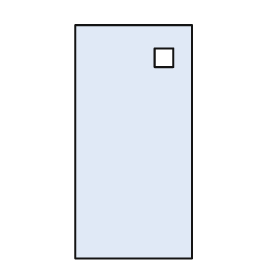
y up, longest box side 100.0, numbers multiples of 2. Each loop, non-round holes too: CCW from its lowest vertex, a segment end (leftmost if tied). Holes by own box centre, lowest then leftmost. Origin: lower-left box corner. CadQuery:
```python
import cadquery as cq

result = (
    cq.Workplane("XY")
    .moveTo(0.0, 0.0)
    .lineTo(50.0, 0.0)
    .lineTo(50.0, 100.0)
    .lineTo(0.0, 100.0)
    .close()
    .moveTo(34.0, 82.0)
    .lineTo(42.0, 82.0)
    .lineTo(42.0, 90.0)
    .lineTo(34.0, 90.0)
    .close()
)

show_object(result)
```